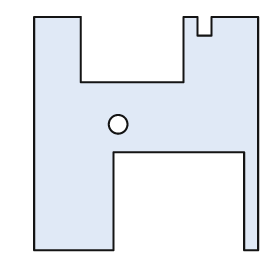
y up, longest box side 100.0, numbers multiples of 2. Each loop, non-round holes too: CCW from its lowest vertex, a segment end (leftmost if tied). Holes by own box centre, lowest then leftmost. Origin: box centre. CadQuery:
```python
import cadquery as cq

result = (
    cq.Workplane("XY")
    .moveTo(-48.0, -50.0)
    .lineTo(-14.0, -50.0)
    .lineTo(-14.0, -8.0)
    .lineTo(42.0, -8.0)
    .lineTo(42.0, -50.0)
    .lineTo(48.0, -50.0)
    .lineTo(48.0, 50.0)
    .lineTo(28.0, 50.0)
    .lineTo(28.0, 42.0)
    .lineTo(22.0, 42.0)
    .lineTo(22.0, 50.0)
    .lineTo(16.0, 50.0)
    .lineTo(16.0, 22.0)
    .lineTo(-28.0, 22.0)
    .lineTo(-28.0, 50.0)
    .lineTo(-48.0, 50.0)
    .close()
    .moveTo(-12.0, 4.0)
    .circle(4.0)
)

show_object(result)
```